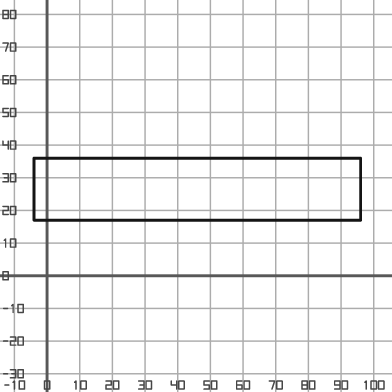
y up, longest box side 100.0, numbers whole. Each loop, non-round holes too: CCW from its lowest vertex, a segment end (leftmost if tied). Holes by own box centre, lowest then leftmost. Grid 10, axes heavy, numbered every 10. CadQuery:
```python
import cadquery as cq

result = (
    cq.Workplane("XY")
    .moveTo(-4.0, 17.0)
    .lineTo(96.0, 17.0)
    .lineTo(96.0, 36.0)
    .lineTo(-4.0, 36.0)
    .close()
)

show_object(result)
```